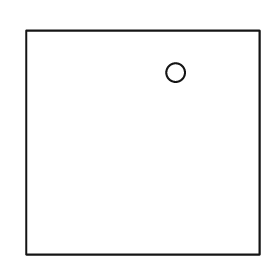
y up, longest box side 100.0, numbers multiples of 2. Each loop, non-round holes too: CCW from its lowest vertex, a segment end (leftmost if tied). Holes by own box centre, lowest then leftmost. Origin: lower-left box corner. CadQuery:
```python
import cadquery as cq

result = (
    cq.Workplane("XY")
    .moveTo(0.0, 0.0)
    .lineTo(100.0, 0.0)
    .lineTo(100.0, 96.0)
    .lineTo(0.0, 96.0)
    .close()
    .moveTo(64.0, 78.0)
    .circle(4.0)
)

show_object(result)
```